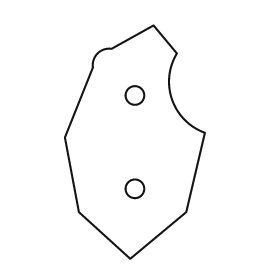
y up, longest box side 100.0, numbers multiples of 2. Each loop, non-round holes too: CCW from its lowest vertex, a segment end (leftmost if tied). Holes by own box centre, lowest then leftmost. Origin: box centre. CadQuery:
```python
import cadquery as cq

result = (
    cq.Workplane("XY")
    .moveTo(-2.0, -50.0)
    .lineTo(22.0, -30.0)
    .lineTo(30.0, 4.0)
    .threePointArc((16.0, 18.0), (18.0, 38.0))
    .lineTo(8.0, 50.0)
    .lineTo(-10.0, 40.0)
    .threePointArc((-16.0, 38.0), (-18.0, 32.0))
    .lineTo(-30.0, 2.0)
    .lineTo(-24.0, -30.0)
    .close()
    .moveTo(0.0, -20.0)
    .circle(4.0)
    .moveTo(0.0, 20.0)
    .circle(4.0)
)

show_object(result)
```